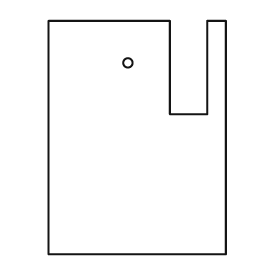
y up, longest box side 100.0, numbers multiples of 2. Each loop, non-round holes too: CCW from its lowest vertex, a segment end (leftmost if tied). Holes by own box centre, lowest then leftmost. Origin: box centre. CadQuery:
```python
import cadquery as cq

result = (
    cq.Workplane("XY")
    .moveTo(-38.0, -50.0)
    .lineTo(38.0, -50.0)
    .lineTo(38.0, 50.0)
    .lineTo(30.0, 50.0)
    .lineTo(30.0, 10.0)
    .lineTo(14.0, 10.0)
    .lineTo(14.0, 50.0)
    .lineTo(-38.0, 50.0)
    .close()
    .moveTo(-4.0, 32.0)
    .circle(2.0)
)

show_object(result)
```